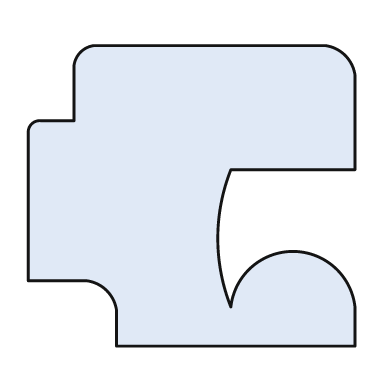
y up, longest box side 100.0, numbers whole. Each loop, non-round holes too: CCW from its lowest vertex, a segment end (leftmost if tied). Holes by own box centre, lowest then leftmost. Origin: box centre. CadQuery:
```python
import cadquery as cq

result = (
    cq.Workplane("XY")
    .moveTo(-23.0, -46.0)
    .lineTo(50.0, -46.0)
    .lineTo(50.0, -34.0)
    .threePointArc((31.0, -17.0), (12.0, -34.0))
    .threePointArc((8.0, -13.0), (12.0, 8.0))
    .lineTo(50.0, 8.0)
    .lineTo(50.0, 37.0)
    .threePointArc((47.0, 43.0), (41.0, 46.0))
    .lineTo(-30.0, 46.0)
    .threePointArc((-34.0, 44.0), (-36.0, 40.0))
    .lineTo(-36.0, 23.0)
    .lineTo(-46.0, 23.0)
    .threePointArc((-49.0, 22.0), (-50.0, 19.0))
    .lineTo(-50.0, -26.0)
    .lineTo(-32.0, -26.0)
    .threePointArc((-26.0, -29.0), (-23.0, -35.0))
    .close()
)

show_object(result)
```